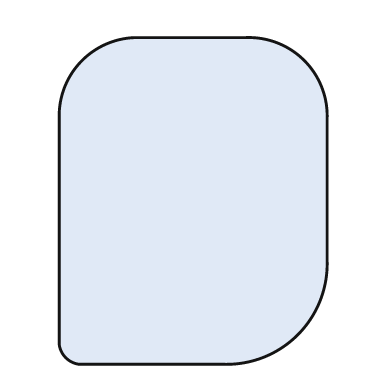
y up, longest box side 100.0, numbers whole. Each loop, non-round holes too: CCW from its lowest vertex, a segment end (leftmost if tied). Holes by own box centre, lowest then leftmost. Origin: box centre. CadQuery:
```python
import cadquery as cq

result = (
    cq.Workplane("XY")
    .moveTo(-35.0, -50.0)
    .lineTo(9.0, -50.0)
    .threePointArc((32.0, -41.0), (41.0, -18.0))
    .lineTo(41.0, 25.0)
    .threePointArc((34.0, 43.0), (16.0, 50.0))
    .lineTo(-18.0, 50.0)
    .threePointArc((-34.0, 43.0), (-41.0, 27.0))
    .lineTo(-41.0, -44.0)
    .threePointArc((-39.0, -48.0), (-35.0, -50.0))
    .close()
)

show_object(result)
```